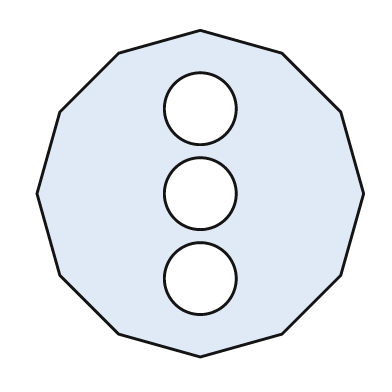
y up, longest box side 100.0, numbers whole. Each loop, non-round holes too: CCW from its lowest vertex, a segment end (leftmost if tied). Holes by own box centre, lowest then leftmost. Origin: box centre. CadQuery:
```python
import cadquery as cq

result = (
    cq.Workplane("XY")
    .moveTo(0.0, -50.0)
    .lineTo(25.0, -43.0)
    .lineTo(43.0, -25.0)
    .lineTo(50.0, 0.0)
    .lineTo(43.0, 25.0)
    .lineTo(25.0, 43.0)
    .lineTo(0.0, 50.0)
    .lineTo(-25.0, 43.0)
    .lineTo(-43.0, 25.0)
    .lineTo(-50.0, 0.0)
    .lineTo(-43.0, -25.0)
    .lineTo(-25.0, -43.0)
    .close()
    .moveTo(0.0, -26.0)
    .circle(11.0)
    .moveTo(0.0, 0.0)
    .circle(11.0)
    .moveTo(0.0, 26.0)
    .circle(11.0)
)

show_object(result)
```